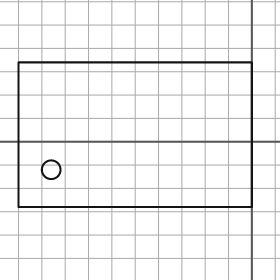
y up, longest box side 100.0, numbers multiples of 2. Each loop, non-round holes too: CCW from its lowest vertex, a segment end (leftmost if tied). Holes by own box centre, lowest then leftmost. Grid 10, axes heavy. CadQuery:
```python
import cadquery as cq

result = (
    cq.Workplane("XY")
    .moveTo(-100.0, -28.0)
    .lineTo(0.0, -28.0)
    .lineTo(0.0, 34.0)
    .lineTo(-100.0, 34.0)
    .close()
    .moveTo(-86.0, -12.0)
    .circle(4.0)
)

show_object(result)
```